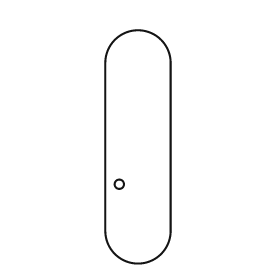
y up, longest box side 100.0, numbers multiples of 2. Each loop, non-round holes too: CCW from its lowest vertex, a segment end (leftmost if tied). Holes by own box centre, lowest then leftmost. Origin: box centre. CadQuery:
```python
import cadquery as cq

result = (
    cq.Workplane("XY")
    .moveTo(-14.0, -36.0)
    .threePointArc((0.0, -50.0), (14.0, -36.0))
    .lineTo(14.0, 36.0)
    .threePointArc((0.0, 50.0), (-14.0, 36.0))
    .close()
    .moveTo(-8.0, -16.0)
    .circle(2.0)
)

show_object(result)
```